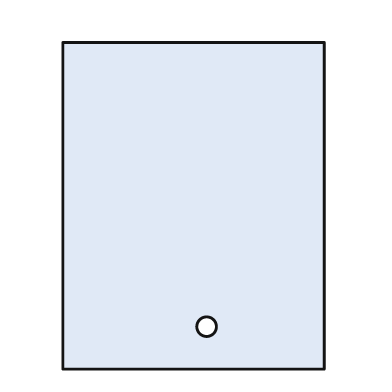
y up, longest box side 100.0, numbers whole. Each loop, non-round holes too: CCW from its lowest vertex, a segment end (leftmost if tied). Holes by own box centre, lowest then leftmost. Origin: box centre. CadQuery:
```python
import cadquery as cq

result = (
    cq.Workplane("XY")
    .moveTo(-40.0, -50.0)
    .lineTo(40.0, -50.0)
    .lineTo(40.0, 50.0)
    .lineTo(-40.0, 50.0)
    .close()
    .moveTo(4.0, -37.0)
    .circle(3.0)
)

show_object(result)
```